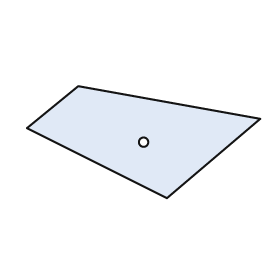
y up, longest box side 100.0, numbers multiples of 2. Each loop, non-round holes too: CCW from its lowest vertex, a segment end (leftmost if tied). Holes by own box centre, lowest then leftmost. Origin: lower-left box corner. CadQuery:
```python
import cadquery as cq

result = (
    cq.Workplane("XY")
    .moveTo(60.0, 0.0)
    .lineTo(100.0, 34.0)
    .lineTo(22.0, 48.0)
    .lineTo(0.0, 30.0)
    .close()
    .moveTo(50.0, 24.0)
    .circle(2.0)
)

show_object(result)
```